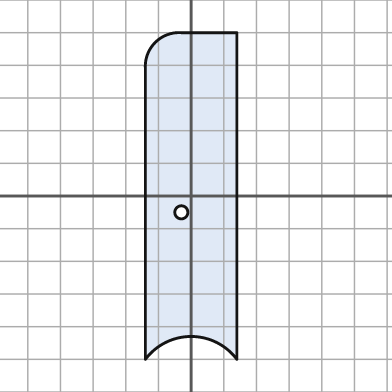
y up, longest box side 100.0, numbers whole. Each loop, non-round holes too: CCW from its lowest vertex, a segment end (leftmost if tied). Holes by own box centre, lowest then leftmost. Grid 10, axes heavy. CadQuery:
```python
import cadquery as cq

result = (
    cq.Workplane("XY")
    .moveTo(-14.0, -50.0)
    .threePointArc((0.0, -43.0), (14.0, -50.0))
    .lineTo(14.0, 50.0)
    .lineTo(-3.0, 50.0)
    .threePointArc((-11.0, 47.0), (-14.0, 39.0))
    .close()
    .moveTo(-3.0, -5.0)
    .circle(2.0)
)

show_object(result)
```